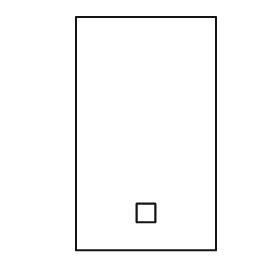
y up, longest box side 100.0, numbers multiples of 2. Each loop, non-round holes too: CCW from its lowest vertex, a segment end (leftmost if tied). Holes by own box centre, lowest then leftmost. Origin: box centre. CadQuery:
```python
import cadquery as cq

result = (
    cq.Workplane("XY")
    .moveTo(-30.0, -50.0)
    .lineTo(30.0, -50.0)
    .lineTo(30.0, 50.0)
    .lineTo(-30.0, 50.0)
    .close()
    .moveTo(-4.0, -38.0)
    .lineTo(4.0, -38.0)
    .lineTo(4.0, -30.0)
    .lineTo(-4.0, -30.0)
    .close()
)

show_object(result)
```